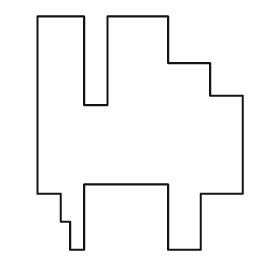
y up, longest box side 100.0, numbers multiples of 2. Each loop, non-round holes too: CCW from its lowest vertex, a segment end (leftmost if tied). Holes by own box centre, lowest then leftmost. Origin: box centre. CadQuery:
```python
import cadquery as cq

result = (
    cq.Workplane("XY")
    .moveTo(-30.0, -50.0)
    .lineTo(-24.0, -50.0)
    .lineTo(-24.0, -22.0)
    .lineTo(12.0, -22.0)
    .lineTo(12.0, -50.0)
    .lineTo(26.0, -50.0)
    .lineTo(26.0, -26.0)
    .lineTo(44.0, -26.0)
    .lineTo(44.0, 16.0)
    .lineTo(30.0, 16.0)
    .lineTo(30.0, 30.0)
    .lineTo(12.0, 30.0)
    .lineTo(12.0, 50.0)
    .lineTo(-14.0, 50.0)
    .lineTo(-14.0, 12.0)
    .lineTo(-24.0, 12.0)
    .lineTo(-24.0, 50.0)
    .lineTo(-44.0, 50.0)
    .lineTo(-44.0, -26.0)
    .lineTo(-34.0, -26.0)
    .lineTo(-34.0, -38.0)
    .lineTo(-30.0, -38.0)
    .close()
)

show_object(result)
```